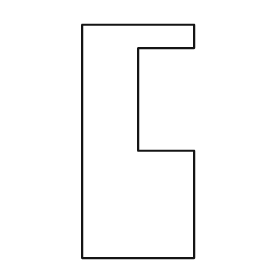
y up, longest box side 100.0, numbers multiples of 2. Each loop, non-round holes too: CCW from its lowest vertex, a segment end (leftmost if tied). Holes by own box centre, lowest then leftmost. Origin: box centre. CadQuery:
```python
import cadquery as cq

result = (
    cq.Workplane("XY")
    .moveTo(-24.0, -50.0)
    .lineTo(24.0, -50.0)
    .lineTo(24.0, -4.0)
    .lineTo(0.0, -4.0)
    .lineTo(0.0, 40.0)
    .lineTo(24.0, 40.0)
    .lineTo(24.0, 50.0)
    .lineTo(-24.0, 50.0)
    .close()
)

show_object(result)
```